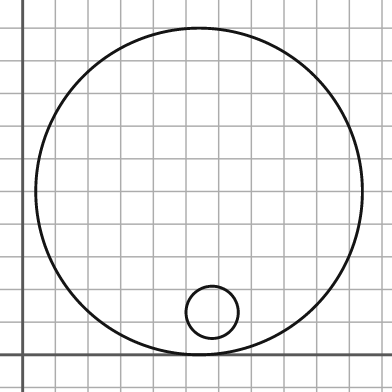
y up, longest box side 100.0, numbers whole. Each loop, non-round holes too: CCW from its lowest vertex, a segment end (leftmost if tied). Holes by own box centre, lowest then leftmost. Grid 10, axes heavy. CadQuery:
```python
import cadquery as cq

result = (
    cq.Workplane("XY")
    .moveTo(54.0, 50.0)
    .circle(50.0)
    .moveTo(58.0, 13.0)
    .circle(8.0)
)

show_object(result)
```